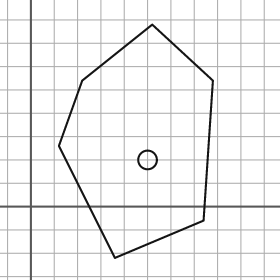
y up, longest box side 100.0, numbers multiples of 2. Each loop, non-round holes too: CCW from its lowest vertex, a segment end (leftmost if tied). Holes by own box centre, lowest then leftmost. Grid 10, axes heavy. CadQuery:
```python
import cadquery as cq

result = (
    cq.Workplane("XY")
    .moveTo(36.0, -22.0)
    .lineTo(74.0, -6.0)
    .lineTo(78.0, 54.0)
    .lineTo(52.0, 78.0)
    .lineTo(22.0, 54.0)
    .lineTo(12.0, 26.0)
    .close()
    .moveTo(50.0, 20.0)
    .circle(4.0)
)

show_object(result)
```